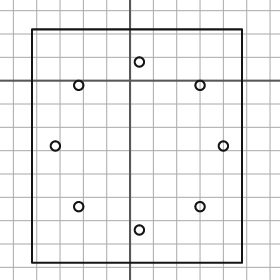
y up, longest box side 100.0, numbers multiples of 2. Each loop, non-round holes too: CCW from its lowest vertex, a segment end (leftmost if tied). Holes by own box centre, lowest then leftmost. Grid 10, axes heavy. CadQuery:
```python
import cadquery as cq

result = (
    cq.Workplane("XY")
    .moveTo(-42.0, -78.0)
    .lineTo(48.0, -78.0)
    .lineTo(48.0, 22.0)
    .lineTo(-42.0, 22.0)
    .close()
    .moveTo(4.0, -64.0)
    .circle(2.0)
    .moveTo(-22.0, -54.0)
    .circle(2.0)
    .moveTo(30.0, -54.0)
    .circle(2.0)
    .moveTo(-32.0, -28.0)
    .circle(2.0)
    .moveTo(40.0, -28.0)
    .circle(2.0)
    .moveTo(-22.0, -2.0)
    .circle(2.0)
    .moveTo(30.0, -2.0)
    .circle(2.0)
    .moveTo(4.0, 8.0)
    .circle(2.0)
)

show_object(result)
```